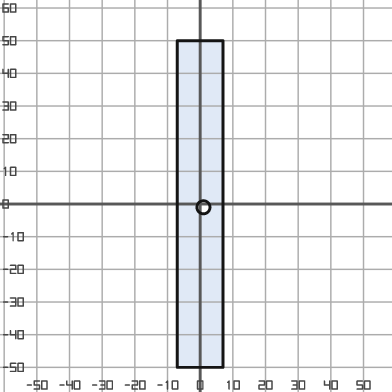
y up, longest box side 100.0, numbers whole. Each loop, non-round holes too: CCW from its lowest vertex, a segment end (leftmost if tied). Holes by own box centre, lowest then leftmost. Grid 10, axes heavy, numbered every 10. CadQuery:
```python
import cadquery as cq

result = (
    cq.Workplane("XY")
    .moveTo(-7.0, -50.0)
    .lineTo(7.0, -50.0)
    .lineTo(7.0, 50.0)
    .lineTo(-7.0, 50.0)
    .close()
    .moveTo(1.0, -1.0)
    .circle(2.0)
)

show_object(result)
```